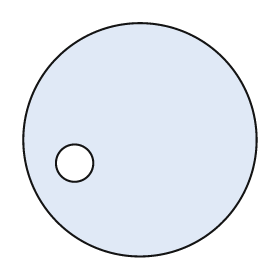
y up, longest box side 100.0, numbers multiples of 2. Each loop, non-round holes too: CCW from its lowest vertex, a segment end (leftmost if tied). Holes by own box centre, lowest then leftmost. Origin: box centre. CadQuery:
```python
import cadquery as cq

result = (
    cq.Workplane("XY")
    .moveTo(0.0, 0.0)
    .circle(50.0)
    .moveTo(-28.0, -10.0)
    .circle(8.0)
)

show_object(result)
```